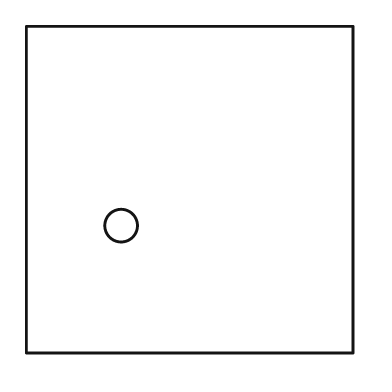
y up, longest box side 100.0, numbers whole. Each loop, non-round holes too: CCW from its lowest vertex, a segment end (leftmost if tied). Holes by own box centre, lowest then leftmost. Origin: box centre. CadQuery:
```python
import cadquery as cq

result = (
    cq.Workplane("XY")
    .moveTo(-50.0, -50.0)
    .lineTo(50.0, -50.0)
    .lineTo(50.0, 50.0)
    .lineTo(-50.0, 50.0)
    .close()
    .moveTo(-21.0, -11.0)
    .circle(5.0)
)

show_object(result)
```